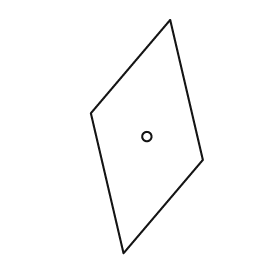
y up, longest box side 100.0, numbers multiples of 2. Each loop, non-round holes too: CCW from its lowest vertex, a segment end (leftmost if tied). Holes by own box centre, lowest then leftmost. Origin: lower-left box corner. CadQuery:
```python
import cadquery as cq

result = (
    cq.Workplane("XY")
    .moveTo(14.0, 0.0)
    .lineTo(48.0, 40.0)
    .lineTo(34.0, 100.0)
    .lineTo(0.0, 60.0)
    .close()
    .moveTo(24.0, 50.0)
    .circle(2.0)
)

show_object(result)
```